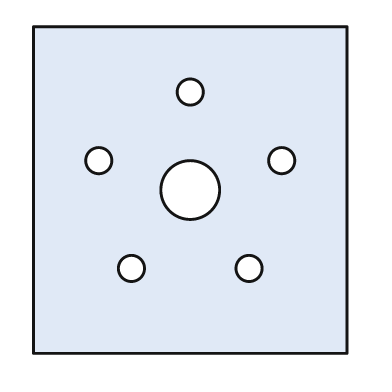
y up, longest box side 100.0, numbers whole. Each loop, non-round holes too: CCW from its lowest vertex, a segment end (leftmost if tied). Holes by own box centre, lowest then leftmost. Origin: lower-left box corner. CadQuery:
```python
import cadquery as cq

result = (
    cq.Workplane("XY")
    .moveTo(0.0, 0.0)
    .lineTo(96.0, 0.0)
    .lineTo(96.0, 100.0)
    .lineTo(0.0, 100.0)
    .close()
    .moveTo(30.0, 26.0)
    .circle(4.0)
    .moveTo(66.0, 26.0)
    .circle(4.0)
    .moveTo(48.0, 50.0)
    .circle(9.0)
    .moveTo(20.0, 59.0)
    .circle(4.0)
    .moveTo(76.0, 59.0)
    .circle(4.0)
    .moveTo(48.0, 80.0)
    .circle(4.0)
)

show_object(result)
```